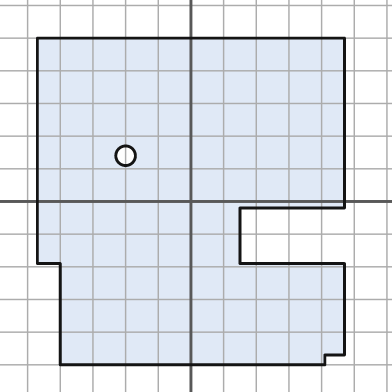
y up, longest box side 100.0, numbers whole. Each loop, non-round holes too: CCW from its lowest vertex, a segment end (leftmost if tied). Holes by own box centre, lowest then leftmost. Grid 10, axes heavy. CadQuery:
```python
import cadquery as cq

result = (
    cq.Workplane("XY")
    .moveTo(-40.0, -50.0)
    .lineTo(41.0, -50.0)
    .lineTo(41.0, -47.0)
    .lineTo(47.0, -47.0)
    .lineTo(47.0, -19.0)
    .lineTo(15.0, -19.0)
    .lineTo(15.0, -2.0)
    .lineTo(47.0, -2.0)
    .lineTo(47.0, 50.0)
    .lineTo(-47.0, 50.0)
    .lineTo(-47.0, -19.0)
    .lineTo(-40.0, -19.0)
    .close()
    .moveTo(-20.0, 14.0)
    .circle(3.0)
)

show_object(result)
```